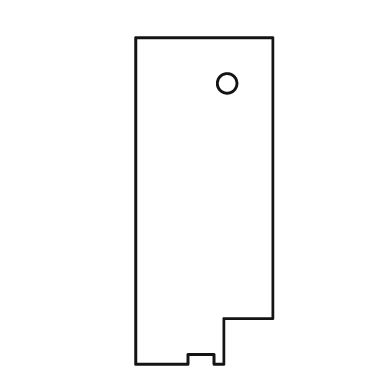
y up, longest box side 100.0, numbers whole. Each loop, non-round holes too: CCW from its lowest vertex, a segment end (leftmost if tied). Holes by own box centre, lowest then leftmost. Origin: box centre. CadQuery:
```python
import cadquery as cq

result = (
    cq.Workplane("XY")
    .moveTo(-21.0, -50.0)
    .lineTo(-5.0, -50.0)
    .lineTo(-5.0, -47.0)
    .lineTo(3.0, -47.0)
    .lineTo(3.0, -50.0)
    .lineTo(6.0, -50.0)
    .lineTo(6.0, -36.0)
    .lineTo(21.0, -36.0)
    .lineTo(21.0, 50.0)
    .lineTo(-21.0, 50.0)
    .close()
    .moveTo(7.0, 36.0)
    .circle(3.0)
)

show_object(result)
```